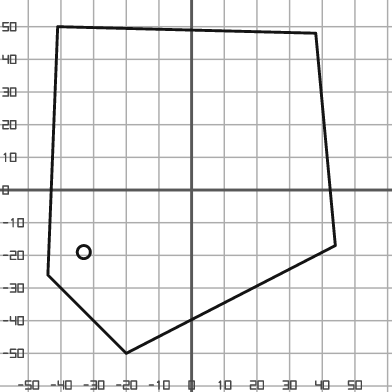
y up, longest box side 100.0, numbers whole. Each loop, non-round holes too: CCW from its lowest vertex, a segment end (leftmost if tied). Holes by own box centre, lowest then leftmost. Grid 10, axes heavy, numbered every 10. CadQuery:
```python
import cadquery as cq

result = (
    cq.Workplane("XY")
    .moveTo(-20.0, -50.0)
    .lineTo(44.0, -17.0)
    .lineTo(38.0, 48.0)
    .lineTo(-41.0, 50.0)
    .lineTo(-44.0, -26.0)
    .close()
    .moveTo(-33.0, -19.0)
    .circle(2.0)
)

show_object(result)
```